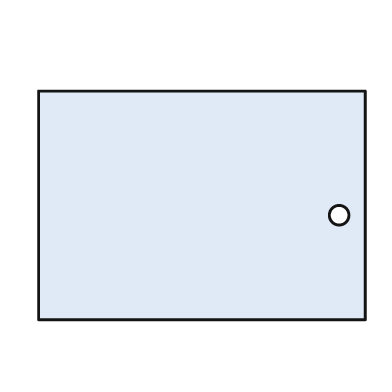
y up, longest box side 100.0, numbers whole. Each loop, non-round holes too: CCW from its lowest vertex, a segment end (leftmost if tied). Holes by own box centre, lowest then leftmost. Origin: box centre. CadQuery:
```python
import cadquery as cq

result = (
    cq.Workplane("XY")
    .moveTo(-50.0, -35.0)
    .lineTo(50.0, -35.0)
    .lineTo(50.0, 35.0)
    .lineTo(-50.0, 35.0)
    .close()
    .moveTo(42.0, -3.0)
    .circle(3.0)
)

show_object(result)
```